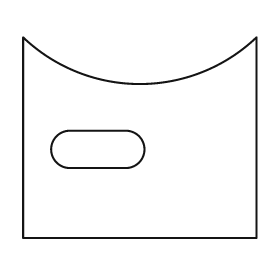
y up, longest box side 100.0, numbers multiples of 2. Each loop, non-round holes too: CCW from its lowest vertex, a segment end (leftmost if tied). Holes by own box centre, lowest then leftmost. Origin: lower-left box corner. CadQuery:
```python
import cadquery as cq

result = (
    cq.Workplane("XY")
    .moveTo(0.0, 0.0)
    .lineTo(100.0, 0.0)
    .lineTo(100.0, 86.0)
    .threePointArc((50.0, 66.0), (0.0, 86.0))
    .close()
    .moveTo(20.0, 30.0)
    .lineTo(44.0, 30.0)
    .threePointArc((52.0, 38.0), (44.0, 46.0))
    .lineTo(20.0, 46.0)
    .threePointArc((12.0, 38.0), (20.0, 30.0))
    .close()
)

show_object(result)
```